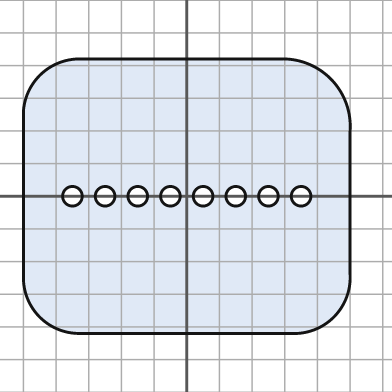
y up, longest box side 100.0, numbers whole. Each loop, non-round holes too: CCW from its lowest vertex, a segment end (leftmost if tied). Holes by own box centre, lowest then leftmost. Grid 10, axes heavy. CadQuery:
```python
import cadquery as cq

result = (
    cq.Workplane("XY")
    .moveTo(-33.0, -42.0)
    .lineTo(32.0, -42.0)
    .threePointArc((45.0, -37.0), (50.0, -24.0))
    .lineTo(50.0, 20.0)
    .threePointArc((44.0, 36.0), (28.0, 42.0))
    .lineTo(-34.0, 42.0)
    .threePointArc((-45.0, 37.0), (-50.0, 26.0))
    .lineTo(-50.0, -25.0)
    .threePointArc((-45.0, -37.0), (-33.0, -42.0))
    .close()
    .moveTo(-35.0, 0.0)
    .circle(3.0)
    .moveTo(-25.0, 0.0)
    .circle(3.0)
    .moveTo(-15.0, 0.0)
    .circle(3.0)
    .moveTo(-5.0, 0.0)
    .circle(3.0)
    .moveTo(5.0, 0.0)
    .circle(3.0)
    .moveTo(15.0, 0.0)
    .circle(3.0)
    .moveTo(25.0, 0.0)
    .circle(3.0)
    .moveTo(35.0, 0.0)
    .circle(3.0)
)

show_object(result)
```